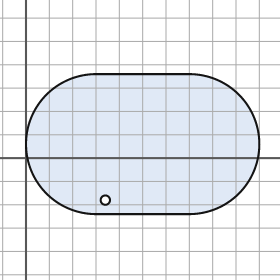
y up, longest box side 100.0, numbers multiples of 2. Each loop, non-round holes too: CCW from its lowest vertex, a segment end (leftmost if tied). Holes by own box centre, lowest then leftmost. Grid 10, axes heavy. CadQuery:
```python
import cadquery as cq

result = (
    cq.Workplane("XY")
    .moveTo(30.0, -24.0)
    .lineTo(70.0, -24.0)
    .threePointArc((100.0, 6.0), (70.0, 36.0))
    .lineTo(30.0, 36.0)
    .threePointArc((0.0, 6.0), (30.0, -24.0))
    .close()
    .moveTo(34.0, -18.0)
    .circle(2.0)
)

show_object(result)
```